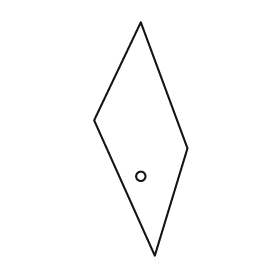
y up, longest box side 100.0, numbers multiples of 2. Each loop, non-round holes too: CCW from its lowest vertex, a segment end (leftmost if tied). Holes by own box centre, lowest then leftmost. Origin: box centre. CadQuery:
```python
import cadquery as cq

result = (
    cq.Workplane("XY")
    .moveTo(6.0, -50.0)
    .lineTo(20.0, -4.0)
    .lineTo(0.0, 50.0)
    .lineTo(-20.0, 8.0)
    .close()
    .moveTo(0.0, -16.0)
    .circle(2.0)
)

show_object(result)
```